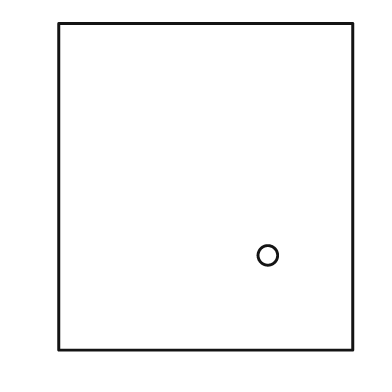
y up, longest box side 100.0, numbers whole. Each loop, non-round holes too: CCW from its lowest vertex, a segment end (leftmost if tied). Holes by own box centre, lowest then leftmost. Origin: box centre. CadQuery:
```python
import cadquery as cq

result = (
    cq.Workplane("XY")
    .moveTo(-45.0, -50.0)
    .lineTo(45.0, -50.0)
    .lineTo(45.0, 50.0)
    .lineTo(-45.0, 50.0)
    .close()
    .moveTo(19.0, -21.0)
    .circle(3.0)
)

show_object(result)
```